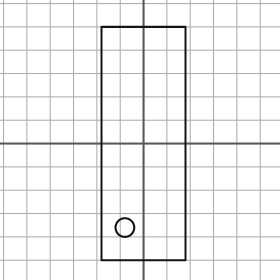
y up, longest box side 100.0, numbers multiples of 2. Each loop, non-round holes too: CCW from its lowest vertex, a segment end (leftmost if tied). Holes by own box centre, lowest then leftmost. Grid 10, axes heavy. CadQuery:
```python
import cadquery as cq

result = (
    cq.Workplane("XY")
    .moveTo(-18.0, -50.0)
    .lineTo(18.0, -50.0)
    .lineTo(18.0, 50.0)
    .lineTo(-18.0, 50.0)
    .close()
    .moveTo(-8.0, -36.0)
    .circle(4.0)
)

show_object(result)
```